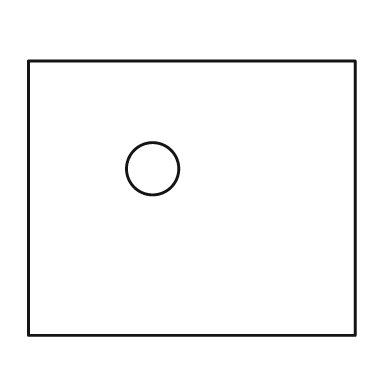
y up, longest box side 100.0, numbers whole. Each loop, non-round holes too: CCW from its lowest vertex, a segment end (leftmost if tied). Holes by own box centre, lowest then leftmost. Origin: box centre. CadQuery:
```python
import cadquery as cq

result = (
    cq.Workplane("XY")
    .moveTo(-50.0, -42.0)
    .lineTo(50.0, -42.0)
    .lineTo(50.0, 42.0)
    .lineTo(-50.0, 42.0)
    .close()
    .moveTo(-12.0, 9.0)
    .circle(8.0)
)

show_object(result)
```